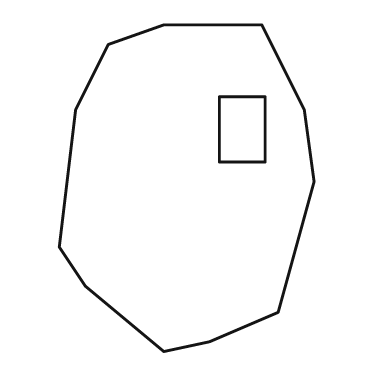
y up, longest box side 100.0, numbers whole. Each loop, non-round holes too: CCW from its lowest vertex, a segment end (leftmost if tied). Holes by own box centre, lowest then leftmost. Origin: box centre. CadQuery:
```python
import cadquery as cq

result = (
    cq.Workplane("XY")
    .moveTo(-7.0, -50.0)
    .lineTo(7.0, -47.0)
    .lineTo(28.0, -38.0)
    .lineTo(39.0, 2.0)
    .lineTo(36.0, 24.0)
    .lineTo(23.0, 50.0)
    .lineTo(-7.0, 50.0)
    .lineTo(-24.0, 44.0)
    .lineTo(-34.0, 24.0)
    .lineTo(-39.0, -18.0)
    .lineTo(-31.0, -30.0)
    .close()
    .moveTo(10.0, 8.0)
    .lineTo(24.0, 8.0)
    .lineTo(24.0, 28.0)
    .lineTo(10.0, 28.0)
    .close()
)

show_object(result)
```